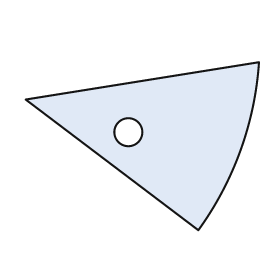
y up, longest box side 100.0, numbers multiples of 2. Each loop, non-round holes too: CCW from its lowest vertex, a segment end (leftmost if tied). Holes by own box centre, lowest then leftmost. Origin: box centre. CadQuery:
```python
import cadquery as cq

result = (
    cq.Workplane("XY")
    .moveTo(24.0, -36.0)
    .threePointArc((42.0, -2.0), (50.0, 36.0))
    .lineTo(-50.0, 20.0)
    .close()
    .moveTo(-6.0, 6.0)
    .circle(6.0)
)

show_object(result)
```